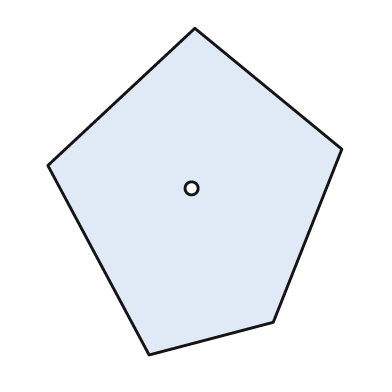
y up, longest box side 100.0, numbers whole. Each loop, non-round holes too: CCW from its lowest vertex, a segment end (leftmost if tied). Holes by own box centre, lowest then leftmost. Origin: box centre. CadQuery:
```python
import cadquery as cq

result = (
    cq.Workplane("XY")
    .moveTo(-14.0, -50.0)
    .lineTo(24.0, -40.0)
    .lineTo(45.0, 13.0)
    .lineTo(0.0, 50.0)
    .lineTo(-45.0, 8.0)
    .close()
    .moveTo(-1.0, 1.0)
    .circle(2.0)
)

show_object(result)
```